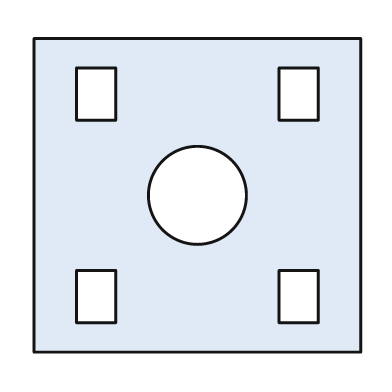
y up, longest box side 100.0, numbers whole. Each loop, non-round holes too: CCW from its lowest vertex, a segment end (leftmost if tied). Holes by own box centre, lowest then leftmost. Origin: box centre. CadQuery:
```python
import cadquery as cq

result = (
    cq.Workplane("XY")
    .moveTo(-50.0, -48.0)
    .lineTo(50.0, -48.0)
    .lineTo(50.0, 48.0)
    .lineTo(-50.0, 48.0)
    .close()
    .moveTo(-37.0, -39.0)
    .lineTo(-25.0, -39.0)
    .lineTo(-25.0, -23.0)
    .lineTo(-37.0, -23.0)
    .close()
    .moveTo(25.0, -39.0)
    .lineTo(37.0, -39.0)
    .lineTo(37.0, -23.0)
    .lineTo(25.0, -23.0)
    .close()
    .moveTo(0.0, 0.0)
    .circle(15.0)
    .moveTo(-37.0, 23.0)
    .lineTo(-25.0, 23.0)
    .lineTo(-25.0, 39.0)
    .lineTo(-37.0, 39.0)
    .close()
    .moveTo(25.0, 23.0)
    .lineTo(37.0, 23.0)
    .lineTo(37.0, 39.0)
    .lineTo(25.0, 39.0)
    .close()
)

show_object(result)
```